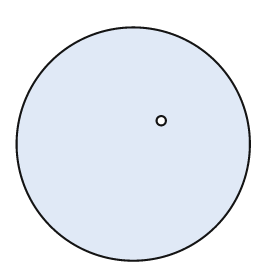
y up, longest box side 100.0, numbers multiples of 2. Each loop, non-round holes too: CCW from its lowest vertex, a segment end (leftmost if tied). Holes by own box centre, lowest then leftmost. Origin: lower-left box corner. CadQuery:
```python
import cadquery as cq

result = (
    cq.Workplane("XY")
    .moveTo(50.0, 50.0)
    .circle(50.0)
    .moveTo(62.0, 60.0)
    .circle(2.0)
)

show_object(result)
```